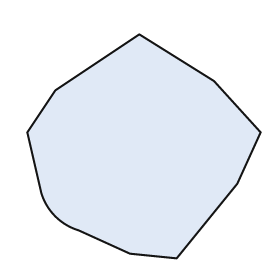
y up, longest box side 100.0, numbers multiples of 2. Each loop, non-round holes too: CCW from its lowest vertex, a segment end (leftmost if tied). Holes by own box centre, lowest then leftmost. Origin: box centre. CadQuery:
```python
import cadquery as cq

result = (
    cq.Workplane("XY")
    .moveTo(14.0, -48.0)
    .lineTo(40.0, -16.0)
    .lineTo(50.0, 6.0)
    .lineTo(30.0, 28.0)
    .lineTo(-2.0, 48.0)
    .lineTo(-38.0, 24.0)
    .lineTo(-50.0, 6.0)
    .lineTo(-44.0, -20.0)
    .threePointArc((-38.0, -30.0), (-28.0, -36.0))
    .lineTo(-6.0, -46.0)
    .close()
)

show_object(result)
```